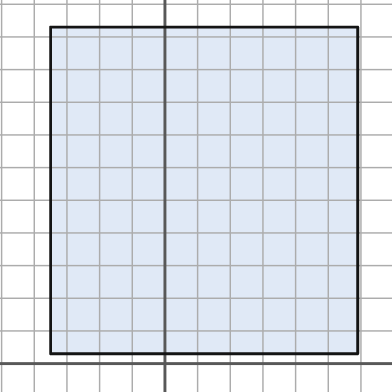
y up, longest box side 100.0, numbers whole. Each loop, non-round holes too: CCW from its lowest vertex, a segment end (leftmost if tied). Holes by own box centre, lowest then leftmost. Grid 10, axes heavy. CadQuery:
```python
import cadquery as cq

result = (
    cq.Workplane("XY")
    .moveTo(-35.0, 3.0)
    .lineTo(59.0, 3.0)
    .lineTo(59.0, 103.0)
    .lineTo(-35.0, 103.0)
    .close()
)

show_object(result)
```